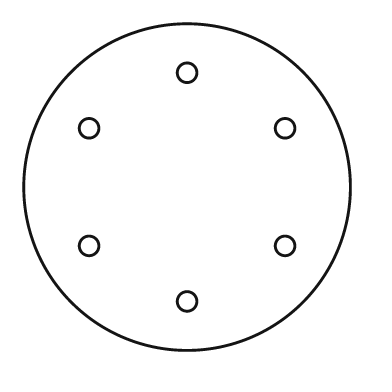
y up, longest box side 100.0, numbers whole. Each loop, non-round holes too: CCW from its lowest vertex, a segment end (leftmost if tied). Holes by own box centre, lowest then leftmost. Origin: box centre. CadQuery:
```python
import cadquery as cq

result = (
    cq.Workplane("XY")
    .moveTo(0.0, 0.0)
    .circle(50.0)
    .moveTo(0.0, -35.0)
    .circle(3.0)
    .moveTo(-30.0, -18.0)
    .circle(3.0)
    .moveTo(30.0, -18.0)
    .circle(3.0)
    .moveTo(-30.0, 18.0)
    .circle(3.0)
    .moveTo(30.0, 18.0)
    .circle(3.0)
    .moveTo(0.0, 35.0)
    .circle(3.0)
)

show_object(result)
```